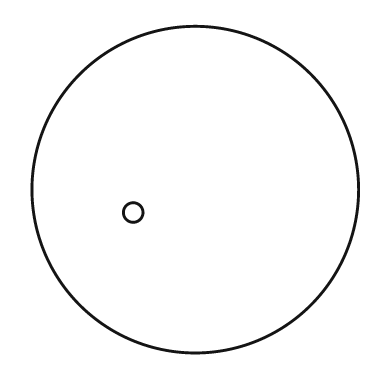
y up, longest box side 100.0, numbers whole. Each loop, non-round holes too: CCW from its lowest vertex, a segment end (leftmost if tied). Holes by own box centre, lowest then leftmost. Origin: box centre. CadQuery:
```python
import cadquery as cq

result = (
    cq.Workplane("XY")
    .moveTo(0.0, 0.0)
    .circle(50.0)
    .moveTo(-19.0, -7.0)
    .circle(3.0)
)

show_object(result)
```